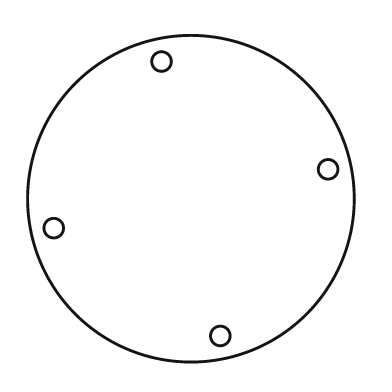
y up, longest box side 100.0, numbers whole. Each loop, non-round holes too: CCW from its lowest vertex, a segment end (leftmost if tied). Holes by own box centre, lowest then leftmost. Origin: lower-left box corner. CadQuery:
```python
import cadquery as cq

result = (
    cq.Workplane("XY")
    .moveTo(50.0, 50.0)
    .circle(50.0)
    .moveTo(59.0, 8.0)
    .circle(3.0)
    .moveTo(8.0, 41.0)
    .circle(3.0)
    .moveTo(92.0, 59.0)
    .circle(3.0)
    .moveTo(41.0, 92.0)
    .circle(3.0)
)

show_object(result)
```